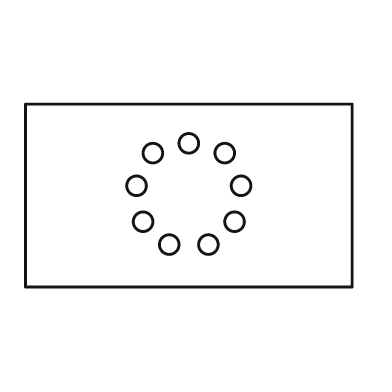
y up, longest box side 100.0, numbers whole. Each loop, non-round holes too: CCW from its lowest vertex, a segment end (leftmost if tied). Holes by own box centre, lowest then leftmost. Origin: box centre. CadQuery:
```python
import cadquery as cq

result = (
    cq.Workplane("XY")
    .moveTo(-50.0, -28.0)
    .lineTo(50.0, -28.0)
    .lineTo(50.0, 28.0)
    .lineTo(-50.0, 28.0)
    .close()
    .moveTo(-6.0, -15.0)
    .circle(3.0)
    .moveTo(6.0, -15.0)
    .circle(3.0)
    .moveTo(-14.0, -8.0)
    .circle(3.0)
    .moveTo(14.0, -8.0)
    .circle(3.0)
    .moveTo(-16.0, 3.0)
    .circle(3.0)
    .moveTo(16.0, 3.0)
    .circle(3.0)
    .moveTo(-11.0, 13.0)
    .circle(3.0)
    .moveTo(11.0, 13.0)
    .circle(3.0)
    .moveTo(0.0, 16.0)
    .circle(3.0)
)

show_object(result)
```